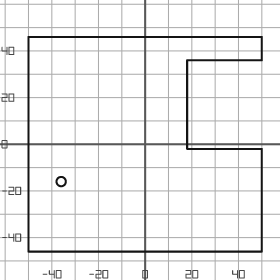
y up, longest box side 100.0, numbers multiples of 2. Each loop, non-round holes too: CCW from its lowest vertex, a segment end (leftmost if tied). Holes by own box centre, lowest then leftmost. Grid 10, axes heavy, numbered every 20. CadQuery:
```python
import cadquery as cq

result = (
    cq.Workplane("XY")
    .moveTo(-50.0, -46.0)
    .lineTo(50.0, -46.0)
    .lineTo(50.0, -2.0)
    .lineTo(18.0, -2.0)
    .lineTo(18.0, 36.0)
    .lineTo(50.0, 36.0)
    .lineTo(50.0, 46.0)
    .lineTo(-50.0, 46.0)
    .close()
    .moveTo(-36.0, -16.0)
    .circle(2.0)
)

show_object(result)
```